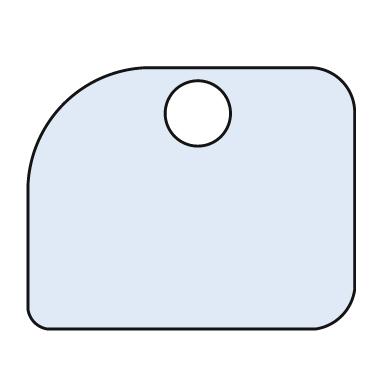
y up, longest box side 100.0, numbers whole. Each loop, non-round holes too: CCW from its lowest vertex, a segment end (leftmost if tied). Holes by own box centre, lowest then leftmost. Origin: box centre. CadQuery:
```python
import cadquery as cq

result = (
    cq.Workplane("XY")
    .moveTo(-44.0, -40.0)
    .lineTo(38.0, -40.0)
    .threePointArc((46.0, -36.0), (50.0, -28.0))
    .lineTo(50.0, 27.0)
    .threePointArc((46.0, 36.0), (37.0, 40.0))
    .lineTo(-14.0, 40.0)
    .threePointArc((-39.0, 29.0), (-50.0, 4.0))
    .lineTo(-50.0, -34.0)
    .threePointArc((-48.0, -38.0), (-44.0, -40.0))
    .close()
    .moveTo(2.0, 26.0)
    .circle(10.0)
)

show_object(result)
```